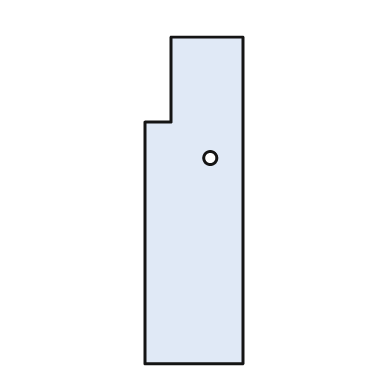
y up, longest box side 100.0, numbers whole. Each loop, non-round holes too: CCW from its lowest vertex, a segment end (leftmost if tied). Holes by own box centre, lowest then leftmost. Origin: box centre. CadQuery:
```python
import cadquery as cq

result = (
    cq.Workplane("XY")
    .moveTo(-15.0, -50.0)
    .lineTo(15.0, -50.0)
    .lineTo(15.0, 50.0)
    .lineTo(-7.0, 50.0)
    .lineTo(-7.0, 24.0)
    .lineTo(-15.0, 24.0)
    .close()
    .moveTo(5.0, 13.0)
    .circle(2.0)
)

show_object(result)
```